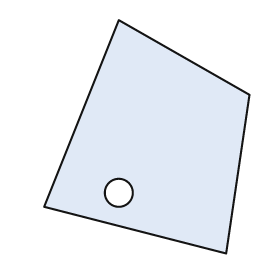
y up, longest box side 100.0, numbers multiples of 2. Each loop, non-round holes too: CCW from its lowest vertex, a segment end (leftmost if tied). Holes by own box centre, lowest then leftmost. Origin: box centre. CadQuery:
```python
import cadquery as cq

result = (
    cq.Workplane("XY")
    .moveTo(34.0, -50.0)
    .lineTo(44.0, 18.0)
    .lineTo(-12.0, 50.0)
    .lineTo(-44.0, -30.0)
    .close()
    .moveTo(-12.0, -24.0)
    .circle(6.0)
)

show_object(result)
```